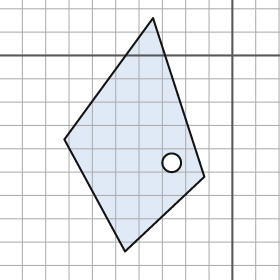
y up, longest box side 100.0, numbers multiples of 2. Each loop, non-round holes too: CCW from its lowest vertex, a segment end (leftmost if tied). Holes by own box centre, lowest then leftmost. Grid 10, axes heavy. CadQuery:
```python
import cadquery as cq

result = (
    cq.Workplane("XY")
    .moveTo(-46.0, -84.0)
    .lineTo(-12.0, -52.0)
    .lineTo(-34.0, 16.0)
    .lineTo(-72.0, -36.0)
    .close()
    .moveTo(-26.0, -46.0)
    .circle(4.0)
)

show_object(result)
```